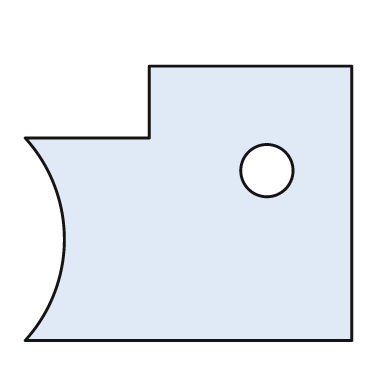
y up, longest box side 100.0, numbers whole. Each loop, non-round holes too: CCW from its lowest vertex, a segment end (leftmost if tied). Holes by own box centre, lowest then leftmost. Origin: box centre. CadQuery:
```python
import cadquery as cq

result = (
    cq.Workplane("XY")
    .moveTo(-50.0, -42.0)
    .lineTo(50.0, -42.0)
    .lineTo(50.0, 42.0)
    .lineTo(-12.0, 42.0)
    .lineTo(-12.0, 20.0)
    .lineTo(-50.0, 20.0)
    .threePointArc((-38.0, -11.0), (-50.0, -42.0))
    .close()
    .moveTo(24.0, 10.0)
    .circle(8.0)
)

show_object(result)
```